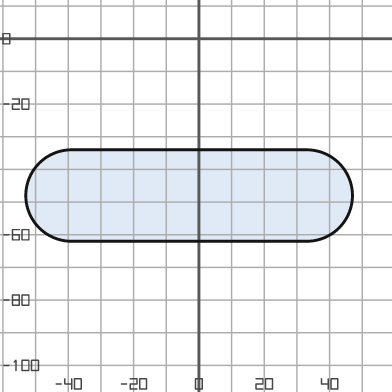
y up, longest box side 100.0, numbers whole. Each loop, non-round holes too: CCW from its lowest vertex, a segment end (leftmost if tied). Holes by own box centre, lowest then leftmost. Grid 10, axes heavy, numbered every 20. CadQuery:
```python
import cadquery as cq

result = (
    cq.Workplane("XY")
    .moveTo(-39.0, -62.0)
    .lineTo(33.0, -62.0)
    .threePointArc((47.0, -48.0), (33.0, -34.0))
    .lineTo(-39.0, -34.0)
    .threePointArc((-53.0, -48.0), (-39.0, -62.0))
    .close()
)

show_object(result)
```